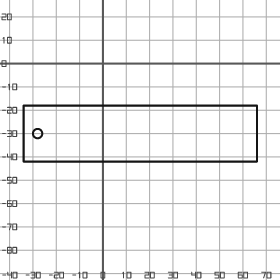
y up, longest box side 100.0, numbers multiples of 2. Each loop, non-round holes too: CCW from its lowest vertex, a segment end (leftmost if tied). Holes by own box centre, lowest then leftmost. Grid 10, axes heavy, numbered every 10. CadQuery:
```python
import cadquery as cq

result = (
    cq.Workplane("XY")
    .moveTo(-34.0, -42.0)
    .lineTo(66.0, -42.0)
    .lineTo(66.0, -18.0)
    .lineTo(-34.0, -18.0)
    .close()
    .moveTo(-28.0, -30.0)
    .circle(2.0)
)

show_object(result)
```